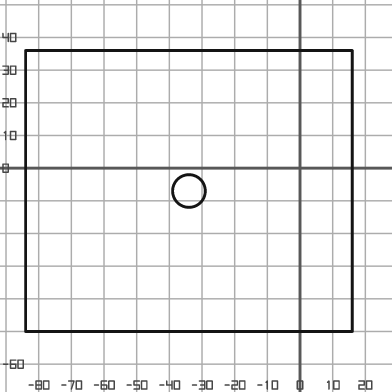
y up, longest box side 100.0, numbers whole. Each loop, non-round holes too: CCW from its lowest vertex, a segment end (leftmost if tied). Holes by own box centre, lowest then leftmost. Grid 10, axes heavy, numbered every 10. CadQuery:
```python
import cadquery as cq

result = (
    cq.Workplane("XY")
    .moveTo(-84.0, -50.0)
    .lineTo(16.0, -50.0)
    .lineTo(16.0, 36.0)
    .lineTo(-84.0, 36.0)
    .close()
    .moveTo(-34.0, -7.0)
    .circle(5.0)
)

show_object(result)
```